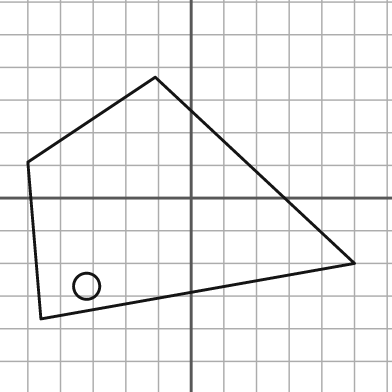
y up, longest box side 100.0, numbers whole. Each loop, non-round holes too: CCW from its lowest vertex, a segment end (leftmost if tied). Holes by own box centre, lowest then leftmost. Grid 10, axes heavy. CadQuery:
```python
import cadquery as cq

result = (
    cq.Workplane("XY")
    .moveTo(-46.0, -37.0)
    .lineTo(50.0, -20.0)
    .lineTo(-11.0, 37.0)
    .lineTo(-50.0, 11.0)
    .close()
    .moveTo(-32.0, -27.0)
    .circle(4.0)
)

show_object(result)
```